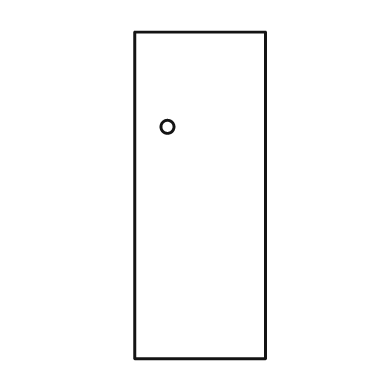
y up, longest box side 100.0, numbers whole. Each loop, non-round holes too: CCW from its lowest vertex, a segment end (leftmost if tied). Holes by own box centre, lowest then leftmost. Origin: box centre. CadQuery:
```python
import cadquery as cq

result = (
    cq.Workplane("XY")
    .moveTo(-20.0, -50.0)
    .lineTo(20.0, -50.0)
    .lineTo(20.0, 50.0)
    .lineTo(-20.0, 50.0)
    .close()
    .moveTo(-10.0, 21.0)
    .circle(2.0)
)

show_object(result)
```